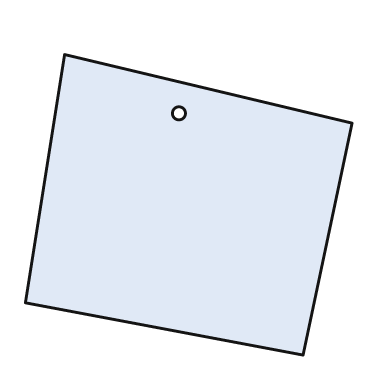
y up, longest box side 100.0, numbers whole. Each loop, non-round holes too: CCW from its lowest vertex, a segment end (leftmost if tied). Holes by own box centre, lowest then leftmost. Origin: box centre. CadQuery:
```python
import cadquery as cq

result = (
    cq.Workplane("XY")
    .moveTo(35.0, -46.0)
    .lineTo(50.0, 25.0)
    .lineTo(-38.0, 46.0)
    .lineTo(-50.0, -30.0)
    .close()
    .moveTo(-3.0, 28.0)
    .circle(2.0)
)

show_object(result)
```